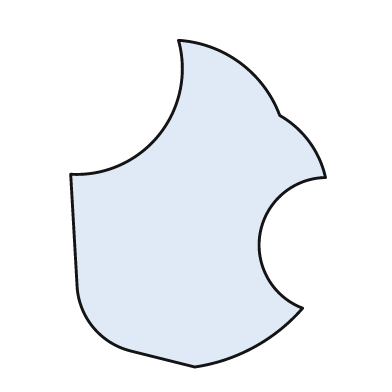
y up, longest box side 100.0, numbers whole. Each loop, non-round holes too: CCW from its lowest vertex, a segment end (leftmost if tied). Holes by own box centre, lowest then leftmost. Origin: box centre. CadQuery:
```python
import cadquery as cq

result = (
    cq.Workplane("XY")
    .moveTo(-1.0, -50.0)
    .threePointArc((17.0, -44.0), (32.0, -32.0))
    .threePointArc((19.0, -9.0), (39.0, 8.0))
    .threePointArc((34.0, 19.0), (25.0, 27.0))
    .threePointArc((13.0, 43.0), (-6.0, 50.0))
    .threePointArc((-12.0, 21.0), (-39.0, 9.0))
    .lineTo(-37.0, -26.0)
    .threePointArc((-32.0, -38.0), (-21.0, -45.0))
    .close()
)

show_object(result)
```